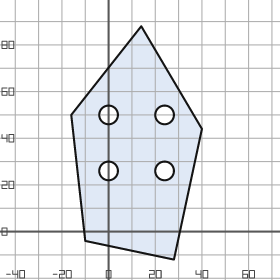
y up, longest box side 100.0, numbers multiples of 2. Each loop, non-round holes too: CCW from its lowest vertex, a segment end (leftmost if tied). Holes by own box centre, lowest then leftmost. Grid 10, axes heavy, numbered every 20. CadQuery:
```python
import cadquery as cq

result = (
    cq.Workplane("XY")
    .moveTo(28.0, -12.0)
    .lineTo(40.0, 44.0)
    .lineTo(14.0, 88.0)
    .lineTo(-16.0, 50.0)
    .lineTo(-10.0, -4.0)
    .close()
    .moveTo(0.0, 26.0)
    .circle(4.0)
    .moveTo(24.0, 26.0)
    .circle(4.0)
    .moveTo(0.0, 50.0)
    .circle(4.0)
    .moveTo(24.0, 50.0)
    .circle(4.0)
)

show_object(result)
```